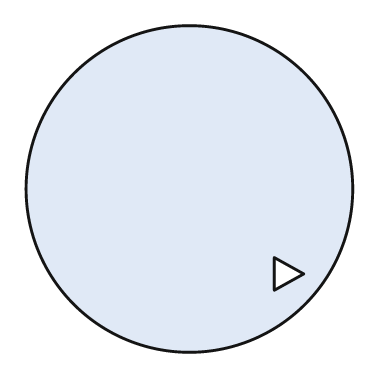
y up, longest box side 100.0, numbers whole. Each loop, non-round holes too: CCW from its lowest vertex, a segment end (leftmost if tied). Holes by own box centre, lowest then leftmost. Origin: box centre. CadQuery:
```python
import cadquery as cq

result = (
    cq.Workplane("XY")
    .moveTo(0.0, 0.0)
    .circle(50.0)
    .moveTo(26.0, -31.0)
    .lineTo(35.0, -26.0)
    .lineTo(26.0, -21.0)
    .close()
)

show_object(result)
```